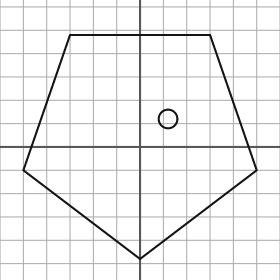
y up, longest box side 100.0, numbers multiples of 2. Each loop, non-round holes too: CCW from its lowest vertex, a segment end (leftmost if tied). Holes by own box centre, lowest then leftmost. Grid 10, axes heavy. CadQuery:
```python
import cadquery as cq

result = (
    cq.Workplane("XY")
    .moveTo(0.0, -48.0)
    .lineTo(50.0, -10.0)
    .lineTo(30.0, 48.0)
    .lineTo(-30.0, 48.0)
    .lineTo(-50.0, -10.0)
    .close()
    .moveTo(12.0, 12.0)
    .circle(4.0)
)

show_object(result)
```